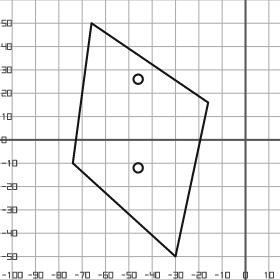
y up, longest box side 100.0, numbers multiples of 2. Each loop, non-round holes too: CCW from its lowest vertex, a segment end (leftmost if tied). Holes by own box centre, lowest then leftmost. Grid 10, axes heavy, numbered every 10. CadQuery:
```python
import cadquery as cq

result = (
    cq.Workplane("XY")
    .moveTo(-30.0, -50.0)
    .lineTo(-16.0, 16.0)
    .lineTo(-66.0, 50.0)
    .lineTo(-74.0, -10.0)
    .close()
    .moveTo(-46.0, -12.0)
    .circle(2.0)
    .moveTo(-46.0, 26.0)
    .circle(2.0)
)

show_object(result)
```